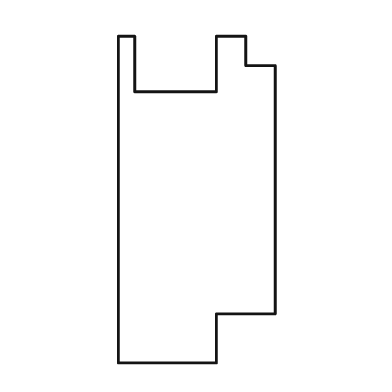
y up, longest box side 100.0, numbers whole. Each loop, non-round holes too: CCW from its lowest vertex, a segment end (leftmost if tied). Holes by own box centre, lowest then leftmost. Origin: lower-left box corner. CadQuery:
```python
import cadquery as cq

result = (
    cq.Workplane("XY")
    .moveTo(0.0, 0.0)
    .lineTo(30.0, 0.0)
    .lineTo(30.0, 15.0)
    .lineTo(48.0, 15.0)
    .lineTo(48.0, 91.0)
    .lineTo(39.0, 91.0)
    .lineTo(39.0, 100.0)
    .lineTo(30.0, 100.0)
    .lineTo(30.0, 83.0)
    .lineTo(5.0, 83.0)
    .lineTo(5.0, 100.0)
    .lineTo(0.0, 100.0)
    .close()
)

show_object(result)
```